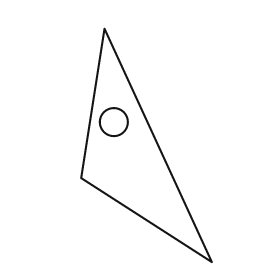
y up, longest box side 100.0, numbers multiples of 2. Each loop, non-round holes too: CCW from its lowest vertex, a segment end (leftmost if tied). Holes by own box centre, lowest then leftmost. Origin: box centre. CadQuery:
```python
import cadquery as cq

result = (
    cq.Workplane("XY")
    .moveTo(28.0, -50.0)
    .lineTo(-18.0, 50.0)
    .lineTo(-28.0, -14.0)
    .close()
    .moveTo(-14.0, 10.0)
    .circle(6.0)
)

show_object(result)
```